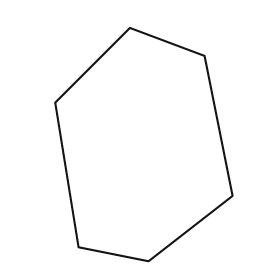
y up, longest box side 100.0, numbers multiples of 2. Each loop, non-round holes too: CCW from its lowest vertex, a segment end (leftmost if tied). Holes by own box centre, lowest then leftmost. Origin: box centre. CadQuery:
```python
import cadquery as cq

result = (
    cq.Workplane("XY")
    .moveTo(2.0, -50.0)
    .lineTo(38.0, -22.0)
    .lineTo(26.0, 38.0)
    .lineTo(-6.0, 50.0)
    .lineTo(-38.0, 18.0)
    .lineTo(-28.0, -44.0)
    .close()
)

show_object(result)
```